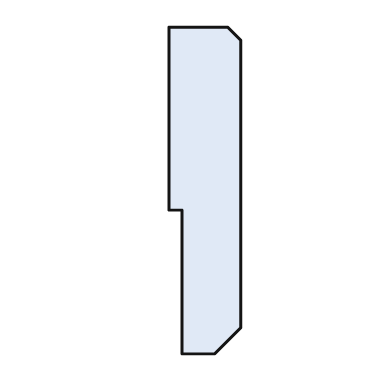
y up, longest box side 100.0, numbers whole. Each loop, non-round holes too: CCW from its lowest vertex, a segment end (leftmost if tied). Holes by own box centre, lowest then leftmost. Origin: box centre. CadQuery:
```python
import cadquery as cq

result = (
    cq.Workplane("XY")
    .moveTo(-7.0, -50.0)
    .lineTo(3.0, -50.0)
    .lineTo(11.0, -42.0)
    .lineTo(11.0, 46.0)
    .lineTo(7.0, 50.0)
    .lineTo(-11.0, 50.0)
    .lineTo(-11.0, -6.0)
    .lineTo(-7.0, -6.0)
    .close()
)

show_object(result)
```